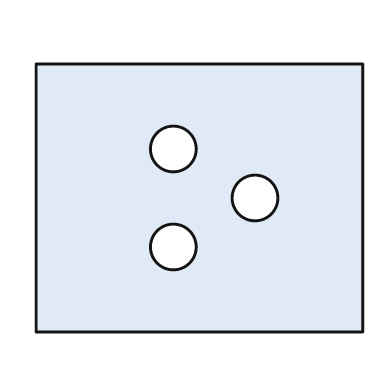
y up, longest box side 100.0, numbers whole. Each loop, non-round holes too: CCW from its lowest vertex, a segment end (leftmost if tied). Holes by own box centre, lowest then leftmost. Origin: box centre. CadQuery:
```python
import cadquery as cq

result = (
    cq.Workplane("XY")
    .moveTo(-50.0, -41.0)
    .lineTo(50.0, -41.0)
    .lineTo(50.0, 41.0)
    .lineTo(-50.0, 41.0)
    .close()
    .moveTo(-8.0, -15.0)
    .circle(7.0)
    .moveTo(17.0, 0.0)
    .circle(7.0)
    .moveTo(-8.0, 15.0)
    .circle(7.0)
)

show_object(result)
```